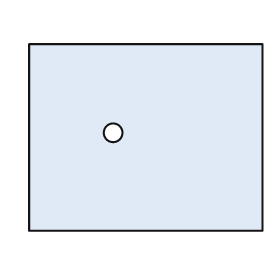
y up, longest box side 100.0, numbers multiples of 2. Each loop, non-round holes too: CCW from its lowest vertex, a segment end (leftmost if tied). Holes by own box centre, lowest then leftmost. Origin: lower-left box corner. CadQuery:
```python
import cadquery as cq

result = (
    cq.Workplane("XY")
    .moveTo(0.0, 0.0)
    .lineTo(100.0, 0.0)
    .lineTo(100.0, 80.0)
    .lineTo(0.0, 80.0)
    .close()
    .moveTo(36.0, 42.0)
    .circle(4.0)
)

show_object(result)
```